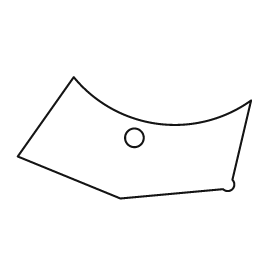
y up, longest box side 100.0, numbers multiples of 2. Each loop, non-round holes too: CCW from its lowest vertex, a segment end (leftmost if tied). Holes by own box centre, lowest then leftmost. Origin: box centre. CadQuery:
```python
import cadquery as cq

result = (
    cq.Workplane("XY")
    .moveTo(-6.0, -26.0)
    .lineTo(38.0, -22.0)
    .threePointArc((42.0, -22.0), (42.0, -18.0))
    .lineTo(50.0, 16.0)
    .threePointArc((10.0, 6.0), (-26.0, 26.0))
    .lineTo(-50.0, -8.0)
    .close()
    .moveTo(0.0, 0.0)
    .circle(4.0)
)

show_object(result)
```